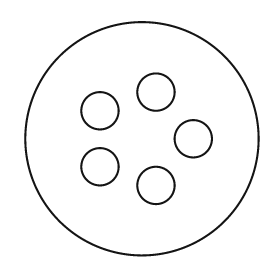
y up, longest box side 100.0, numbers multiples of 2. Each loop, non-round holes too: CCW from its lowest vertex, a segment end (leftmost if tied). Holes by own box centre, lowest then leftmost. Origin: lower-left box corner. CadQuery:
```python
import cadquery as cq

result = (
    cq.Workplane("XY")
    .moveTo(50.0, 50.0)
    .circle(50.0)
    .moveTo(56.0, 30.0)
    .circle(8.0)
    .moveTo(32.0, 38.0)
    .circle(8.0)
    .moveTo(72.0, 50.0)
    .circle(8.0)
    .moveTo(32.0, 62.0)
    .circle(8.0)
    .moveTo(56.0, 70.0)
    .circle(8.0)
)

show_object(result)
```